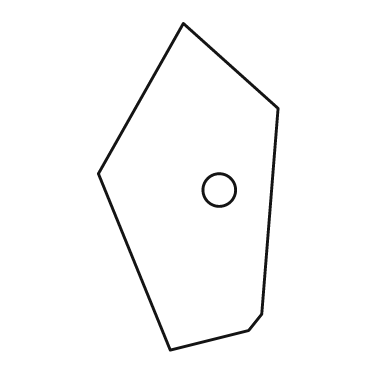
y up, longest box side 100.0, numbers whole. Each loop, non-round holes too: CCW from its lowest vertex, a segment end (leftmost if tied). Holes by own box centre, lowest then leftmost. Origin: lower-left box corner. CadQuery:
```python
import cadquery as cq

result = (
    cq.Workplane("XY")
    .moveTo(22.0, 0.0)
    .lineTo(46.0, 6.0)
    .lineTo(50.0, 11.0)
    .lineTo(55.0, 74.0)
    .lineTo(26.0, 100.0)
    .lineTo(0.0, 54.0)
    .close()
    .moveTo(37.0, 49.0)
    .circle(5.0)
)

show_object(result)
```